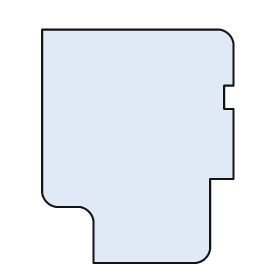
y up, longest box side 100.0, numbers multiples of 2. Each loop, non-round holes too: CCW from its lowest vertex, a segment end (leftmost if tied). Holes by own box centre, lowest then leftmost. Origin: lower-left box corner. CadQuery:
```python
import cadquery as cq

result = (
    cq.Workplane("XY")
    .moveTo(22.0, 0.0)
    .lineTo(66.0, 0.0)
    .threePointArc((70.0, 2.0), (72.0, 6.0))
    .lineTo(72.0, 36.0)
    .lineTo(82.0, 36.0)
    .lineTo(82.0, 66.0)
    .lineTo(78.0, 66.0)
    .lineTo(78.0, 76.0)
    .lineTo(82.0, 76.0)
    .lineTo(82.0, 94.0)
    .threePointArc((80.0, 98.0), (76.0, 100.0))
    .lineTo(0.0, 100.0)
    .lineTo(0.0, 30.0)
    .threePointArc((2.0, 26.0), (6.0, 24.0))
    .lineTo(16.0, 24.0)
    .threePointArc((20.0, 22.0), (22.0, 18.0))
    .close()
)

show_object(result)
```